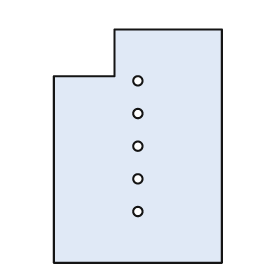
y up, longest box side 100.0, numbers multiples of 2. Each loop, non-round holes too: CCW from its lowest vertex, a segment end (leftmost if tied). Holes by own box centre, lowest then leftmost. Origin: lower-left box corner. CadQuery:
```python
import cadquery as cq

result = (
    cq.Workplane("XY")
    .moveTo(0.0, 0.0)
    .lineTo(72.0, 0.0)
    .lineTo(72.0, 100.0)
    .lineTo(26.0, 100.0)
    .lineTo(26.0, 80.0)
    .lineTo(0.0, 80.0)
    .close()
    .moveTo(36.0, 22.0)
    .circle(2.0)
    .moveTo(36.0, 36.0)
    .circle(2.0)
    .moveTo(36.0, 50.0)
    .circle(2.0)
    .moveTo(36.0, 64.0)
    .circle(2.0)
    .moveTo(36.0, 78.0)
    .circle(2.0)
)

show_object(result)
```